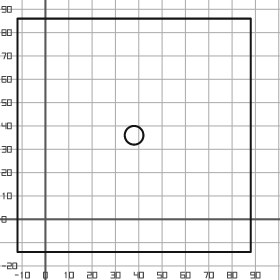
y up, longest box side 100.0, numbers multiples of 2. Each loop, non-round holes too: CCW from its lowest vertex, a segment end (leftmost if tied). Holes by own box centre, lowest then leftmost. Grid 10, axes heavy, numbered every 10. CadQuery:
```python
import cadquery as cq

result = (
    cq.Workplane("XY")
    .moveTo(-12.0, -14.0)
    .lineTo(88.0, -14.0)
    .lineTo(88.0, 86.0)
    .lineTo(-12.0, 86.0)
    .close()
    .moveTo(38.0, 36.0)
    .circle(4.0)
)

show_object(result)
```